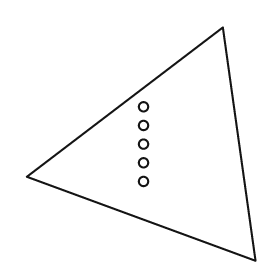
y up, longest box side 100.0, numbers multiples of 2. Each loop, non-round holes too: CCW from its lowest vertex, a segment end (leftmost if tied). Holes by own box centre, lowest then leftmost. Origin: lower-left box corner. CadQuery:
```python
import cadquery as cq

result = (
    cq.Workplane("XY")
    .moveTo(98.0, 0.0)
    .lineTo(84.0, 100.0)
    .lineTo(0.0, 36.0)
    .close()
    .moveTo(50.0, 34.0)
    .circle(2.0)
    .moveTo(50.0, 42.0)
    .circle(2.0)
    .moveTo(50.0, 50.0)
    .circle(2.0)
    .moveTo(50.0, 58.0)
    .circle(2.0)
    .moveTo(50.0, 66.0)
    .circle(2.0)
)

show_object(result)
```